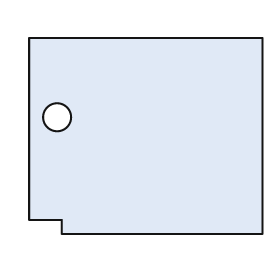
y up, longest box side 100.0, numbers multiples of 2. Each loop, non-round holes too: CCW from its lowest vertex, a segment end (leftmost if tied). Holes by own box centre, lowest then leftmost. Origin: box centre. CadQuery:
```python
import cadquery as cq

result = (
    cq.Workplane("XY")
    .moveTo(-36.0, -42.0)
    .lineTo(50.0, -42.0)
    .lineTo(50.0, 42.0)
    .lineTo(-50.0, 42.0)
    .lineTo(-50.0, -36.0)
    .lineTo(-36.0, -36.0)
    .close()
    .moveTo(-38.0, 8.0)
    .circle(6.0)
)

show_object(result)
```